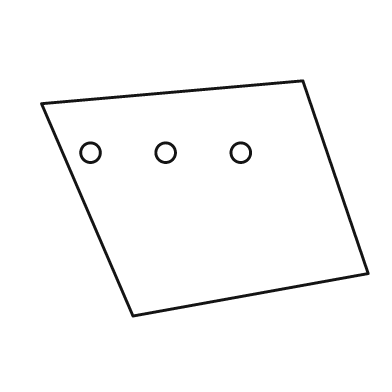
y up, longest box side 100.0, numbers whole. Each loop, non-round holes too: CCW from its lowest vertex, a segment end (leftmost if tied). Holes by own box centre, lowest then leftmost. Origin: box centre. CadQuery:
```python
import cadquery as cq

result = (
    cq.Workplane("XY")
    .moveTo(-22.0, -36.0)
    .lineTo(50.0, -23.0)
    .lineTo(30.0, 36.0)
    .lineTo(-50.0, 29.0)
    .close()
    .moveTo(-35.0, 14.0)
    .circle(3.0)
    .moveTo(-12.0, 14.0)
    .circle(3.0)
    .moveTo(11.0, 14.0)
    .circle(3.0)
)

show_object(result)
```